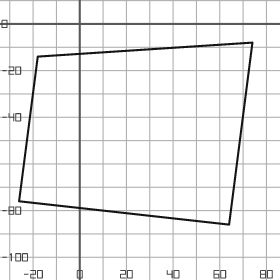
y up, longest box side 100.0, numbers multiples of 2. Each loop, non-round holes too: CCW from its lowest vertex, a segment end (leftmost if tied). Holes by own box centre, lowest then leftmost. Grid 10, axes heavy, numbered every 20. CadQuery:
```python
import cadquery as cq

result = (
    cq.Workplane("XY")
    .moveTo(64.0, -86.0)
    .lineTo(74.0, -8.0)
    .lineTo(-18.0, -14.0)
    .lineTo(-26.0, -76.0)
    .close()
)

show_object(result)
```